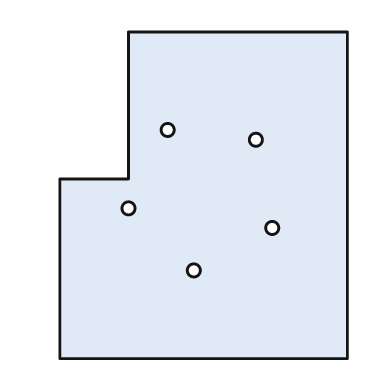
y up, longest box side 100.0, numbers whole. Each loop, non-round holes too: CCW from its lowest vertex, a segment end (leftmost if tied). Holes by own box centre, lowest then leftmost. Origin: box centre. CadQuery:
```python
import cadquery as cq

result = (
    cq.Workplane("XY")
    .moveTo(-44.0, -50.0)
    .lineTo(44.0, -50.0)
    .lineTo(44.0, 50.0)
    .lineTo(-23.0, 50.0)
    .lineTo(-23.0, 5.0)
    .lineTo(-44.0, 5.0)
    .close()
    .moveTo(-3.0, -23.0)
    .circle(2.0)
    .moveTo(21.0, -10.0)
    .circle(2.0)
    .moveTo(-23.0, -4.0)
    .circle(2.0)
    .moveTo(16.0, 17.0)
    .circle(2.0)
    .moveTo(-11.0, 20.0)
    .circle(2.0)
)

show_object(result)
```